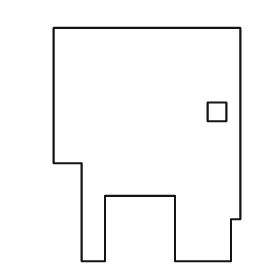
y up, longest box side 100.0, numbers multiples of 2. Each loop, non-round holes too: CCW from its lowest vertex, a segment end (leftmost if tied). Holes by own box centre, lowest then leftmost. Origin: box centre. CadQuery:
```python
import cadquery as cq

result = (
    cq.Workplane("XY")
    .moveTo(-28.0, -50.0)
    .lineTo(-18.0, -50.0)
    .lineTo(-18.0, -22.0)
    .lineTo(12.0, -22.0)
    .lineTo(12.0, -50.0)
    .lineTo(36.0, -50.0)
    .lineTo(36.0, -32.0)
    .lineTo(40.0, -32.0)
    .lineTo(40.0, 50.0)
    .lineTo(-40.0, 50.0)
    .lineTo(-40.0, -8.0)
    .lineTo(-28.0, -8.0)
    .close()
    .moveTo(26.0, 10.0)
    .lineTo(34.0, 10.0)
    .lineTo(34.0, 18.0)
    .lineTo(26.0, 18.0)
    .close()
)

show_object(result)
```